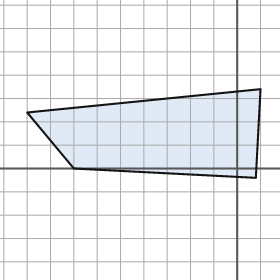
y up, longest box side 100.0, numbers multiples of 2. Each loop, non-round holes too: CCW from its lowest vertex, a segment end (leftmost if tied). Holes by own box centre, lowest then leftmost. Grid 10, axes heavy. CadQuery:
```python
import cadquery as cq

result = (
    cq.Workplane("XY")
    .moveTo(8.0, -4.0)
    .lineTo(10.0, 34.0)
    .lineTo(-90.0, 24.0)
    .lineTo(-70.0, 0.0)
    .close()
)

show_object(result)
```